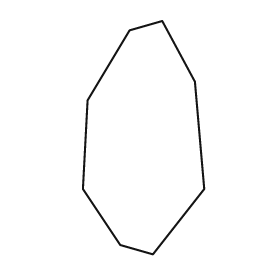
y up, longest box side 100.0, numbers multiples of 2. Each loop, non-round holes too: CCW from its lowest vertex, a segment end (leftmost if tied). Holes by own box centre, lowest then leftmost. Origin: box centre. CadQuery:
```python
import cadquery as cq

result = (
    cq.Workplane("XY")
    .moveTo(4.0, -50.0)
    .lineTo(26.0, -22.0)
    .lineTo(22.0, 24.0)
    .lineTo(8.0, 50.0)
    .lineTo(-6.0, 46.0)
    .lineTo(-24.0, 16.0)
    .lineTo(-26.0, -22.0)
    .lineTo(-10.0, -46.0)
    .close()
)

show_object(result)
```